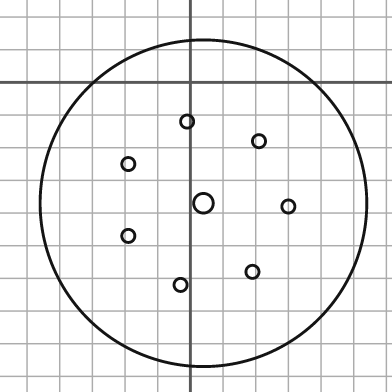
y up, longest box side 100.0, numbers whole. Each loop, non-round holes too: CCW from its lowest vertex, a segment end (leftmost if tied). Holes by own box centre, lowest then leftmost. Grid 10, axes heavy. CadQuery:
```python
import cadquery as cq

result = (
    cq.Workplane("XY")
    .moveTo(4.0, -37.0)
    .circle(50.0)
    .moveTo(-3.0, -62.0)
    .circle(2.0)
    .moveTo(19.0, -58.0)
    .circle(2.0)
    .moveTo(-19.0, -47.0)
    .circle(2.0)
    .moveTo(30.0, -38.0)
    .circle(2.0)
    .moveTo(4.0, -37.0)
    .circle(3.0)
    .moveTo(-19.0, -25.0)
    .circle(2.0)
    .moveTo(21.0, -18.0)
    .circle(2.0)
    .moveTo(-1.0, -12.0)
    .circle(2.0)
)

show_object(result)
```